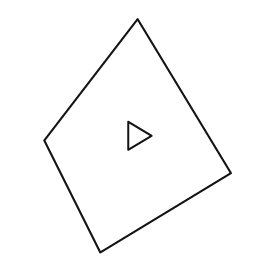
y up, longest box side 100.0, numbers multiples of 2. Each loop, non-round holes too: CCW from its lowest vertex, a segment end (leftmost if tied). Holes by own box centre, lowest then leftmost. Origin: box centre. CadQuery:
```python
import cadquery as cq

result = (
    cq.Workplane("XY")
    .moveTo(-16.0, -50.0)
    .lineTo(40.0, -16.0)
    .lineTo(0.0, 50.0)
    .lineTo(-40.0, -2.0)
    .close()
    .moveTo(-4.0, -6.0)
    .lineTo(6.0, 0.0)
    .lineTo(-4.0, 6.0)
    .close()
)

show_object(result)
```